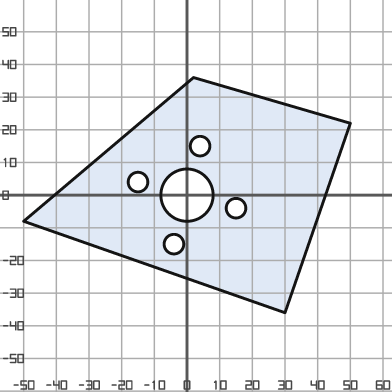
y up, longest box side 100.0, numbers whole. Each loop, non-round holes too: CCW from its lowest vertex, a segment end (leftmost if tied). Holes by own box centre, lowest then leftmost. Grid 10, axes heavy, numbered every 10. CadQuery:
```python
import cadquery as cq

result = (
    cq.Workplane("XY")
    .moveTo(30.0, -36.0)
    .lineTo(50.0, 22.0)
    .lineTo(2.0, 36.0)
    .lineTo(-50.0, -8.0)
    .close()
    .moveTo(-4.0, -15.0)
    .circle(3.0)
    .moveTo(15.0, -4.0)
    .circle(3.0)
    .moveTo(0.0, 0.0)
    .circle(8.0)
    .moveTo(-15.0, 4.0)
    .circle(3.0)
    .moveTo(4.0, 15.0)
    .circle(3.0)
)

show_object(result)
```